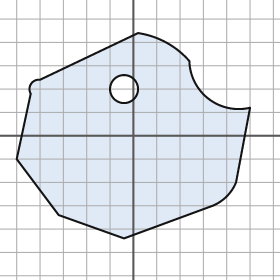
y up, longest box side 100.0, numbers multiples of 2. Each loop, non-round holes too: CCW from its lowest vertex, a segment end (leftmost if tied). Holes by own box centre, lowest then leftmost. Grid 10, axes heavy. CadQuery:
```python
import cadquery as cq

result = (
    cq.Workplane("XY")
    .moveTo(-4.0, -44.0)
    .lineTo(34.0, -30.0)
    .threePointArc((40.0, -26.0), (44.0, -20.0))
    .lineTo(50.0, 12.0)
    .threePointArc((32.0, 16.0), (24.0, 32.0))
    .threePointArc((14.0, 40.0), (2.0, 44.0))
    .lineTo(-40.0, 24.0)
    .threePointArc((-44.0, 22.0), (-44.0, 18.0))
    .lineTo(-50.0, -10.0)
    .lineTo(-32.0, -34.0)
    .close()
    .moveTo(-4.0, 20.0)
    .circle(6.0)
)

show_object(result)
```